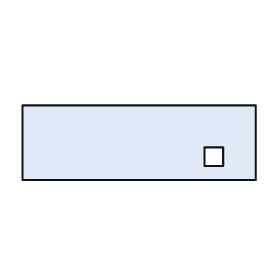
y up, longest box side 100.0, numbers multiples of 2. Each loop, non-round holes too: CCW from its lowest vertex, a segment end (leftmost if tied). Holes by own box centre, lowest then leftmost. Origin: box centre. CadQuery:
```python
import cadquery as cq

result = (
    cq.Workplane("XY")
    .moveTo(-50.0, -16.0)
    .lineTo(50.0, -16.0)
    .lineTo(50.0, 16.0)
    .lineTo(-50.0, 16.0)
    .close()
    .moveTo(28.0, -10.0)
    .lineTo(36.0, -10.0)
    .lineTo(36.0, -2.0)
    .lineTo(28.0, -2.0)
    .close()
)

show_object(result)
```